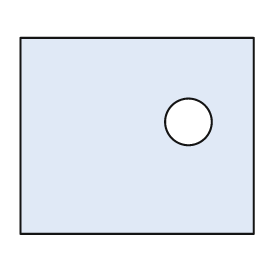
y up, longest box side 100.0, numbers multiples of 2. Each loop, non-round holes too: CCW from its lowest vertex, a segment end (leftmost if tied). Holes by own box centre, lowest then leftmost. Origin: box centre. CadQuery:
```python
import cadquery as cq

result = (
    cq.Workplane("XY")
    .moveTo(-50.0, -42.0)
    .lineTo(50.0, -42.0)
    .lineTo(50.0, 42.0)
    .lineTo(-50.0, 42.0)
    .close()
    .moveTo(22.0, 6.0)
    .circle(10.0)
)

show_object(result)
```